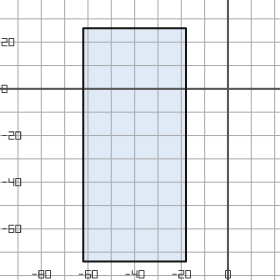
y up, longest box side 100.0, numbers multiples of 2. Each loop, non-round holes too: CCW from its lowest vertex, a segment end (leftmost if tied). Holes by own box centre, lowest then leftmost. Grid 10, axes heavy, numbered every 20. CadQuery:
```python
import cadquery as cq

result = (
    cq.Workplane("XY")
    .moveTo(-62.0, -74.0)
    .lineTo(-18.0, -74.0)
    .lineTo(-18.0, 26.0)
    .lineTo(-62.0, 26.0)
    .close()
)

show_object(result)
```